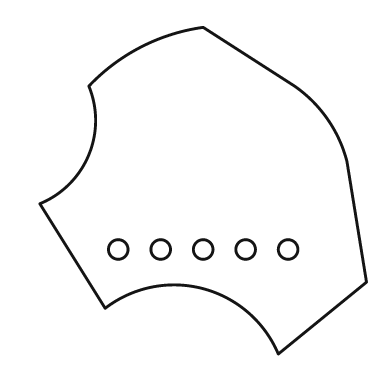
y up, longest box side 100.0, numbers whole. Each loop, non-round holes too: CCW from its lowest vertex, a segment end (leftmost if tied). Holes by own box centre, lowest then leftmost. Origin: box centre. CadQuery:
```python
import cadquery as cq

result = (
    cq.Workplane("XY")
    .moveTo(23.0, -50.0)
    .lineTo(50.0, -28.0)
    .lineTo(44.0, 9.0)
    .threePointArc((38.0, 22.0), (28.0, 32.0))
    .lineTo(0.0, 50.0)
    .threePointArc((-19.0, 44.0), (-35.0, 32.0))
    .threePointArc((-35.0, 11.0), (-50.0, -4.0))
    .lineTo(-30.0, -36.0)
    .threePointArc((0.0, -30.0), (23.0, -50.0))
    .close()
    .moveTo(-26.0, -18.0)
    .circle(3.0)
    .moveTo(-13.0, -18.0)
    .circle(3.0)
    .moveTo(0.0, -18.0)
    .circle(3.0)
    .moveTo(13.0, -18.0)
    .circle(3.0)
    .moveTo(26.0, -18.0)
    .circle(3.0)
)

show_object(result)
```